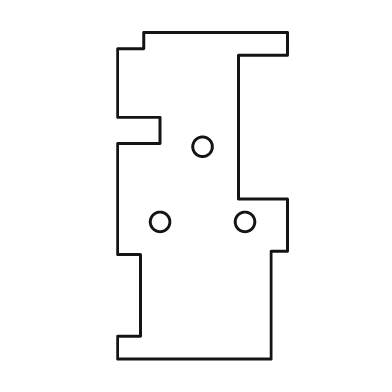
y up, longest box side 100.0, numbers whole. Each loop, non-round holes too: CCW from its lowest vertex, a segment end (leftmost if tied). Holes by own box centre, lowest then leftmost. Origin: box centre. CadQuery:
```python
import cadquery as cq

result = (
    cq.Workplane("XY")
    .moveTo(-26.0, -50.0)
    .lineTo(21.0, -50.0)
    .lineTo(21.0, -17.0)
    .lineTo(26.0, -17.0)
    .lineTo(26.0, -1.0)
    .lineTo(11.0, -1.0)
    .lineTo(11.0, 43.0)
    .lineTo(26.0, 43.0)
    .lineTo(26.0, 50.0)
    .lineTo(-18.0, 50.0)
    .lineTo(-18.0, 45.0)
    .lineTo(-26.0, 45.0)
    .lineTo(-26.0, 24.0)
    .lineTo(-13.0, 24.0)
    .lineTo(-13.0, 16.0)
    .lineTo(-26.0, 16.0)
    .lineTo(-26.0, -18.0)
    .lineTo(-19.0, -18.0)
    .lineTo(-19.0, -43.0)
    .lineTo(-26.0, -43.0)
    .close()
    .moveTo(-13.0, -8.0)
    .circle(3.0)
    .moveTo(13.0, -8.0)
    .circle(3.0)
    .moveTo(0.0, 15.0)
    .circle(3.0)
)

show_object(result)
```